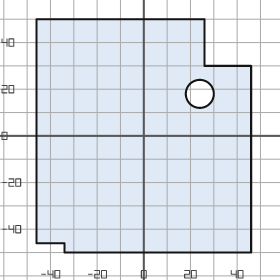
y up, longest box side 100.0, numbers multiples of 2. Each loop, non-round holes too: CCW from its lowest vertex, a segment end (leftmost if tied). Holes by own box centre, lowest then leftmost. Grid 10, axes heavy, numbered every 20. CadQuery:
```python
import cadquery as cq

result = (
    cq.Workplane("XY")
    .moveTo(-34.0, -50.0)
    .lineTo(46.0, -50.0)
    .lineTo(46.0, 30.0)
    .lineTo(26.0, 30.0)
    .lineTo(26.0, 50.0)
    .lineTo(-46.0, 50.0)
    .lineTo(-46.0, -46.0)
    .lineTo(-34.0, -46.0)
    .close()
    .moveTo(24.0, 18.0)
    .circle(6.0)
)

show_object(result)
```